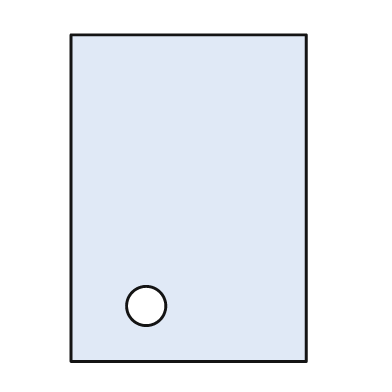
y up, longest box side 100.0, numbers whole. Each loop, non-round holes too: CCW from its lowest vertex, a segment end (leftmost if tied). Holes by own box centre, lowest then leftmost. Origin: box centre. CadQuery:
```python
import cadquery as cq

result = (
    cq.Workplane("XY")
    .moveTo(-36.0, -50.0)
    .lineTo(36.0, -50.0)
    .lineTo(36.0, 50.0)
    .lineTo(-36.0, 50.0)
    .close()
    .moveTo(-13.0, -33.0)
    .circle(6.0)
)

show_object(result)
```